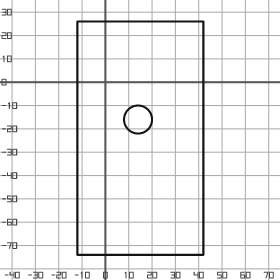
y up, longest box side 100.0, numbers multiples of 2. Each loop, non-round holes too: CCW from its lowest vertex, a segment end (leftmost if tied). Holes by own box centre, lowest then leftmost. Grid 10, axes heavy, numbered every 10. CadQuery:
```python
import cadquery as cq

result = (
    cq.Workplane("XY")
    .moveTo(-12.0, -74.0)
    .lineTo(42.0, -74.0)
    .lineTo(42.0, 26.0)
    .lineTo(-12.0, 26.0)
    .close()
    .moveTo(14.0, -16.0)
    .circle(6.0)
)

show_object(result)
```